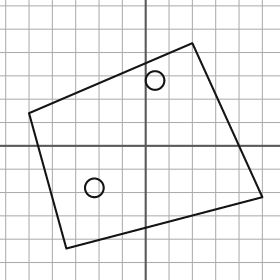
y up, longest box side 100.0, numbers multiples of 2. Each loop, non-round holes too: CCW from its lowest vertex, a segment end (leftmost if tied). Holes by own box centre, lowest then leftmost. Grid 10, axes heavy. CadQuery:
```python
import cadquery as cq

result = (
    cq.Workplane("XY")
    .moveTo(-34.0, -44.0)
    .lineTo(50.0, -22.0)
    .lineTo(20.0, 44.0)
    .lineTo(-50.0, 14.0)
    .close()
    .moveTo(-22.0, -18.0)
    .circle(4.0)
    .moveTo(4.0, 28.0)
    .circle(4.0)
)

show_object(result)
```